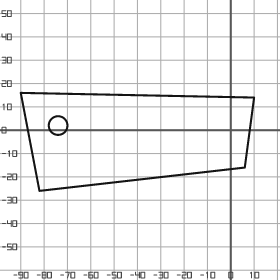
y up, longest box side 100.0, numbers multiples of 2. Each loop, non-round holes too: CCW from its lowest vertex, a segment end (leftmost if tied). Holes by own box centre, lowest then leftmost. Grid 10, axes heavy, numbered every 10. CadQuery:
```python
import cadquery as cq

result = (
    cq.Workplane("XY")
    .moveTo(-82.0, -26.0)
    .lineTo(6.0, -16.0)
    .lineTo(10.0, 14.0)
    .lineTo(-90.0, 16.0)
    .close()
    .moveTo(-74.0, 2.0)
    .circle(4.0)
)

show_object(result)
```